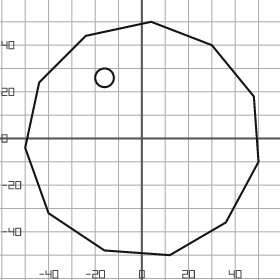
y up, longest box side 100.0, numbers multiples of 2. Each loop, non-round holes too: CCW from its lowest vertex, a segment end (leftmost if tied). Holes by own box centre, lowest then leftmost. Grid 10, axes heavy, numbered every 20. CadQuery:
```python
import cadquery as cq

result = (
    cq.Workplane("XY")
    .moveTo(12.0, -50.0)
    .lineTo(36.0, -36.0)
    .lineTo(50.0, -10.0)
    .lineTo(48.0, 18.0)
    .lineTo(30.0, 40.0)
    .lineTo(4.0, 50.0)
    .lineTo(-24.0, 44.0)
    .lineTo(-44.0, 24.0)
    .lineTo(-50.0, -4.0)
    .lineTo(-40.0, -32.0)
    .lineTo(-16.0, -48.0)
    .close()
    .moveTo(-16.0, 26.0)
    .circle(4.0)
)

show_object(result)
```